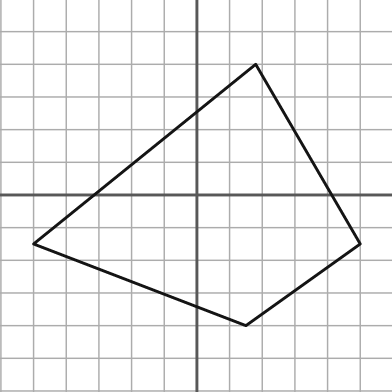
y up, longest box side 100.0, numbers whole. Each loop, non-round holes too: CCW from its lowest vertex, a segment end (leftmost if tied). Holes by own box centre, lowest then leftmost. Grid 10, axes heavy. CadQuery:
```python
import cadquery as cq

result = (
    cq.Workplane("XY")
    .moveTo(15.0, -40.0)
    .lineTo(50.0, -15.0)
    .lineTo(18.0, 40.0)
    .lineTo(-50.0, -15.0)
    .close()
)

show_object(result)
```